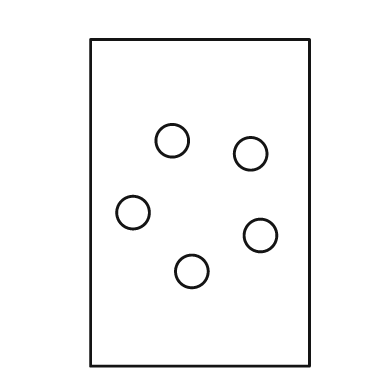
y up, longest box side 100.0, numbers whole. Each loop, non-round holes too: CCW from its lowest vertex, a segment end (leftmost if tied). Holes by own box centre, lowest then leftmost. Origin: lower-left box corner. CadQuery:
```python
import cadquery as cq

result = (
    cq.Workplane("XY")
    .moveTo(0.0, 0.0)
    .lineTo(67.0, 0.0)
    .lineTo(67.0, 100.0)
    .lineTo(0.0, 100.0)
    .close()
    .moveTo(31.0, 29.0)
    .circle(5.0)
    .moveTo(52.0, 40.0)
    .circle(5.0)
    .moveTo(13.0, 47.0)
    .circle(5.0)
    .moveTo(49.0, 65.0)
    .circle(5.0)
    .moveTo(25.0, 69.0)
    .circle(5.0)
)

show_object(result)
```